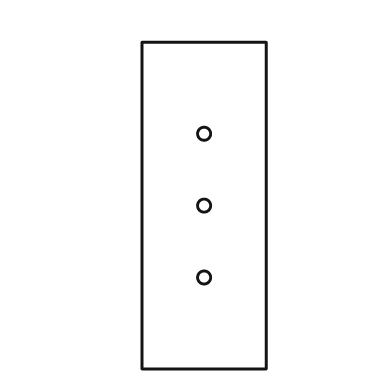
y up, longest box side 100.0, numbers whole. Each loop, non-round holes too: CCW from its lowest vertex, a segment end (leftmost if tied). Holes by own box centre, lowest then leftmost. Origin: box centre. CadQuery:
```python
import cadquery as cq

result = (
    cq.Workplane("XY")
    .moveTo(-19.0, -50.0)
    .lineTo(19.0, -50.0)
    .lineTo(19.0, 50.0)
    .lineTo(-19.0, 50.0)
    .close()
    .moveTo(0.0, -22.0)
    .circle(2.0)
    .moveTo(0.0, 0.0)
    .circle(2.0)
    .moveTo(0.0, 22.0)
    .circle(2.0)
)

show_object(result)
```